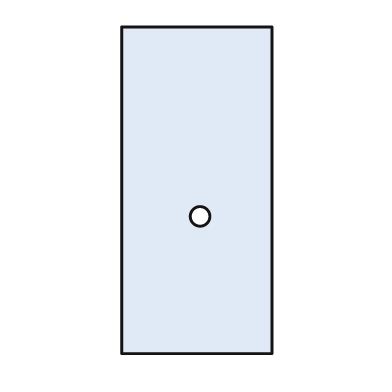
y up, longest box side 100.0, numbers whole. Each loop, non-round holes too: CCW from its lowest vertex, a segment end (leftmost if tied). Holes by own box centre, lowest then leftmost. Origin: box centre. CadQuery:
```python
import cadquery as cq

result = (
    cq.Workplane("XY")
    .moveTo(-23.0, -50.0)
    .lineTo(23.0, -50.0)
    .lineTo(23.0, 50.0)
    .lineTo(-23.0, 50.0)
    .close()
    .moveTo(1.0, -8.0)
    .circle(3.0)
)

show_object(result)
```